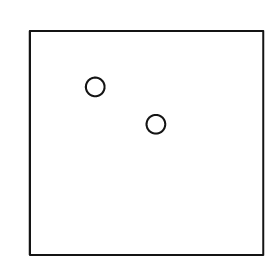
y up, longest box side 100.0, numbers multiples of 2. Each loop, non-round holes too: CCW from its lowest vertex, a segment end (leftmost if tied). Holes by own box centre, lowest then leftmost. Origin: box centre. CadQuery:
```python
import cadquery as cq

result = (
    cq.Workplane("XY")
    .moveTo(-50.0, -48.0)
    .lineTo(50.0, -48.0)
    .lineTo(50.0, 48.0)
    .lineTo(-50.0, 48.0)
    .close()
    .moveTo(4.0, 8.0)
    .circle(4.0)
    .moveTo(-22.0, 24.0)
    .circle(4.0)
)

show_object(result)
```